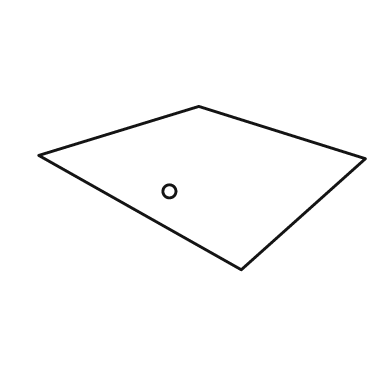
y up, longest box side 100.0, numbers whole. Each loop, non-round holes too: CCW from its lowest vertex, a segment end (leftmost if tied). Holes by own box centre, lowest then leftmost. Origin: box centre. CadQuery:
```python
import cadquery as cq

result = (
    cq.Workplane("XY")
    .moveTo(12.0, -25.0)
    .lineTo(50.0, 9.0)
    .lineTo(-1.0, 25.0)
    .lineTo(-50.0, 10.0)
    .close()
    .moveTo(-10.0, -1.0)
    .circle(2.0)
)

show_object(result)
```